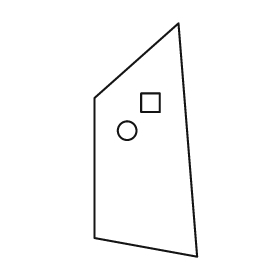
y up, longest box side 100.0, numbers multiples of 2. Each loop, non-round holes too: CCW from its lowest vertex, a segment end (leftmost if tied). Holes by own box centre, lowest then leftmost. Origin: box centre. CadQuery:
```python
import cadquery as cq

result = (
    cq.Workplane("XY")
    .moveTo(22.0, -50.0)
    .lineTo(14.0, 50.0)
    .lineTo(-22.0, 18.0)
    .lineTo(-22.0, -42.0)
    .close()
    .moveTo(-8.0, 4.0)
    .circle(4.0)
    .moveTo(-2.0, 12.0)
    .lineTo(6.0, 12.0)
    .lineTo(6.0, 20.0)
    .lineTo(-2.0, 20.0)
    .close()
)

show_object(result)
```